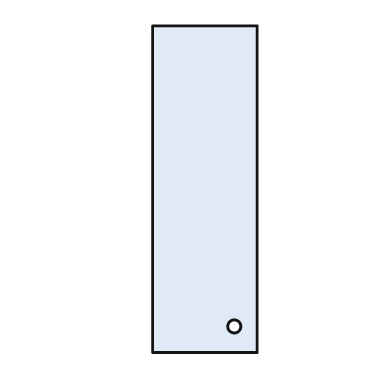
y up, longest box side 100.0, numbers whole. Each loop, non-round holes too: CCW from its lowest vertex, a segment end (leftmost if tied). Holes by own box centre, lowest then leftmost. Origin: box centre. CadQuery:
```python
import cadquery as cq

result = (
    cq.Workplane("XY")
    .moveTo(-16.0, -50.0)
    .lineTo(16.0, -50.0)
    .lineTo(16.0, 50.0)
    .lineTo(-16.0, 50.0)
    .close()
    .moveTo(9.0, -42.0)
    .circle(2.0)
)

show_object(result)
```